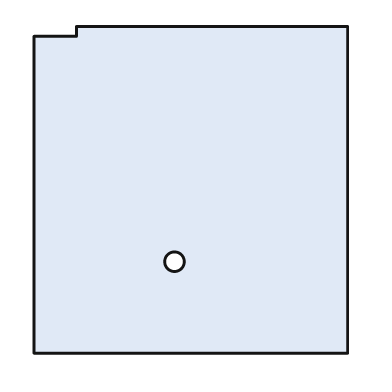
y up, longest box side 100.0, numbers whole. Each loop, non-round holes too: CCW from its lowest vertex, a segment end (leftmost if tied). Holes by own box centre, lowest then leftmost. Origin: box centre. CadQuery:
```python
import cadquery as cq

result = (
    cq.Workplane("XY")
    .moveTo(-48.0, -50.0)
    .lineTo(48.0, -50.0)
    .lineTo(48.0, 50.0)
    .lineTo(-35.0, 50.0)
    .lineTo(-35.0, 47.0)
    .lineTo(-48.0, 47.0)
    .close()
    .moveTo(-5.0, -22.0)
    .circle(3.0)
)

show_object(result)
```